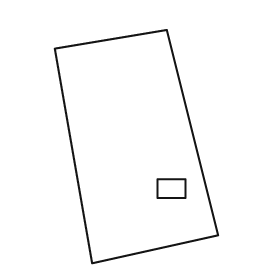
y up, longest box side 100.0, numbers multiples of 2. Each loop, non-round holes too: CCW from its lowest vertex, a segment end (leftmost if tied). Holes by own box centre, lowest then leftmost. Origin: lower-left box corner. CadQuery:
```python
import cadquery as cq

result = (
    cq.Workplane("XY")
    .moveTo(16.0, 0.0)
    .lineTo(70.0, 12.0)
    .lineTo(48.0, 100.0)
    .lineTo(0.0, 92.0)
    .close()
    .moveTo(44.0, 28.0)
    .lineTo(56.0, 28.0)
    .lineTo(56.0, 36.0)
    .lineTo(44.0, 36.0)
    .close()
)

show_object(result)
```